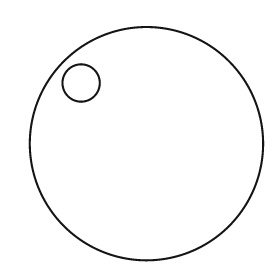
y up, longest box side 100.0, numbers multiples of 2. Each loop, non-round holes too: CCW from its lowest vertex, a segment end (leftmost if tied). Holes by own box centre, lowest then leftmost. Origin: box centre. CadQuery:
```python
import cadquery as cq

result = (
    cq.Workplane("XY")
    .moveTo(0.0, 0.0)
    .circle(50.0)
    .moveTo(-28.0, 26.0)
    .circle(8.0)
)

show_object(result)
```